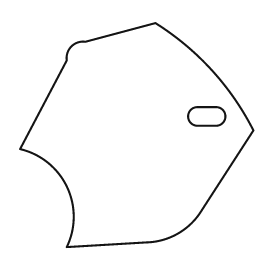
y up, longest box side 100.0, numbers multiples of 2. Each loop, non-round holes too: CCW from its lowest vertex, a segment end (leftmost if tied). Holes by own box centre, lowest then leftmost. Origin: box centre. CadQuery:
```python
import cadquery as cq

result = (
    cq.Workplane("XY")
    .moveTo(-30.0, -48.0)
    .lineTo(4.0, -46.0)
    .threePointArc((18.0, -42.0), (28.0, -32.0))
    .lineTo(50.0, 2.0)
    .threePointArc((32.0, 28.0), (8.0, 48.0))
    .lineTo(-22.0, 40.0)
    .threePointArc((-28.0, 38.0), (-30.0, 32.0))
    .lineTo(-50.0, -6.0)
    .threePointArc((-30.0, -22.0), (-30.0, -48.0))
    .close()
    .moveTo(26.0, 4.0)
    .lineTo(34.0, 4.0)
    .threePointArc((38.0, 8.0), (34.0, 12.0))
    .lineTo(26.0, 12.0)
    .threePointArc((22.0, 8.0), (26.0, 4.0))
    .close()
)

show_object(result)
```